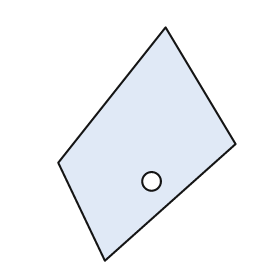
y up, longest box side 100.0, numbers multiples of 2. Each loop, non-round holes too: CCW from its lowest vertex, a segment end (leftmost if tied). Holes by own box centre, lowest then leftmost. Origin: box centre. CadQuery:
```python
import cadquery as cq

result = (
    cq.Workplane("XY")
    .moveTo(-18.0, -50.0)
    .lineTo(38.0, 0.0)
    .lineTo(8.0, 50.0)
    .lineTo(-38.0, -8.0)
    .close()
    .moveTo(2.0, -16.0)
    .circle(4.0)
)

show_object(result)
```